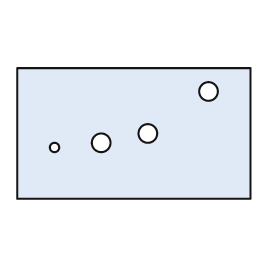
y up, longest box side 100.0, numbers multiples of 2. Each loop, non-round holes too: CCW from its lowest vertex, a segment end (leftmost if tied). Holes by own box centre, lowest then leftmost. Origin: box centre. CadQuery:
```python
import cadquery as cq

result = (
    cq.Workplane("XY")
    .moveTo(-50.0, -28.0)
    .lineTo(50.0, -28.0)
    .lineTo(50.0, 28.0)
    .lineTo(-50.0, 28.0)
    .close()
    .moveTo(-34.0, -6.0)
    .circle(2.0)
    .moveTo(-14.0, -4.0)
    .circle(4.0)
    .moveTo(6.0, 0.0)
    .circle(4.0)
    .moveTo(32.0, 18.0)
    .circle(4.0)
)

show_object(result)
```